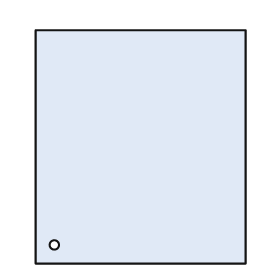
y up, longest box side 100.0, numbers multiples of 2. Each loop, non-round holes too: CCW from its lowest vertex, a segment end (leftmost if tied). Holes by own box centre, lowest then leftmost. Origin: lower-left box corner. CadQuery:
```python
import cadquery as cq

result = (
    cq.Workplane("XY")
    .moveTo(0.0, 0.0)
    .lineTo(90.0, 0.0)
    .lineTo(90.0, 100.0)
    .lineTo(0.0, 100.0)
    .close()
    .moveTo(8.0, 8.0)
    .circle(2.0)
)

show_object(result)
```